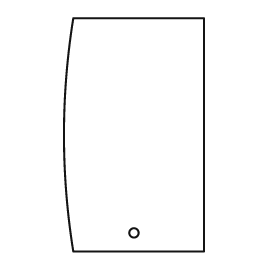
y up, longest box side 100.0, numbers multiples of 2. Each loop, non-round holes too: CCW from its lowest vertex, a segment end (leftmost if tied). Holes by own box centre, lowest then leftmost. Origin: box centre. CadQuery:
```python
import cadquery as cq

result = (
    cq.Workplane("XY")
    .moveTo(-26.0, -50.0)
    .lineTo(30.0, -50.0)
    .lineTo(30.0, 50.0)
    .lineTo(-26.0, 50.0)
    .threePointArc((-30.0, 0.0), (-26.0, -50.0))
    .close()
    .moveTo(0.0, -42.0)
    .circle(2.0)
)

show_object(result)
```